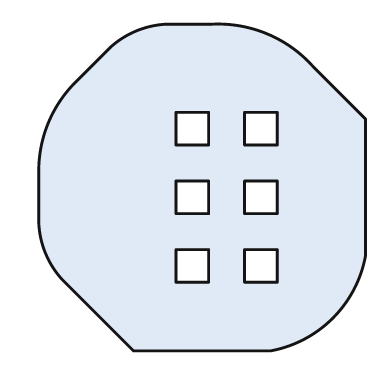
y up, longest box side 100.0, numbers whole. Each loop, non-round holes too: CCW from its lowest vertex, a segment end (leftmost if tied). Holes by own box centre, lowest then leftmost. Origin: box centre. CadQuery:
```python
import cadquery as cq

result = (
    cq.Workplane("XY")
    .moveTo(-21.0, -50.0)
    .lineTo(21.0, -50.0)
    .threePointArc((40.0, -40.0), (50.0, -21.0))
    .lineTo(50.0, 21.0)
    .lineTo(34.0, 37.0)
    .threePointArc((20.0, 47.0), (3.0, 50.0))
    .lineTo(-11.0, 50.0)
    .threePointArc((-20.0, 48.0), (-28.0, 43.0))
    .lineTo(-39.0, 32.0)
    .threePointArc((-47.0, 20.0), (-50.0, 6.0))
    .lineTo(-50.0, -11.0)
    .threePointArc((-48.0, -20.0), (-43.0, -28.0))
    .close()
    .moveTo(-8.0, -29.0)
    .lineTo(2.0, -29.0)
    .lineTo(2.0, -19.0)
    .lineTo(-8.0, -19.0)
    .close()
    .moveTo(13.0, -29.0)
    .lineTo(23.0, -29.0)
    .lineTo(23.0, -19.0)
    .lineTo(13.0, -19.0)
    .close()
    .moveTo(-8.0, -8.0)
    .lineTo(2.0, -8.0)
    .lineTo(2.0, 2.0)
    .lineTo(-8.0, 2.0)
    .close()
    .moveTo(13.0, -8.0)
    .lineTo(23.0, -8.0)
    .lineTo(23.0, 2.0)
    .lineTo(13.0, 2.0)
    .close()
    .moveTo(-8.0, 13.0)
    .lineTo(2.0, 13.0)
    .lineTo(2.0, 23.0)
    .lineTo(-8.0, 23.0)
    .close()
    .moveTo(13.0, 13.0)
    .lineTo(23.0, 13.0)
    .lineTo(23.0, 23.0)
    .lineTo(13.0, 23.0)
    .close()
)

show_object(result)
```